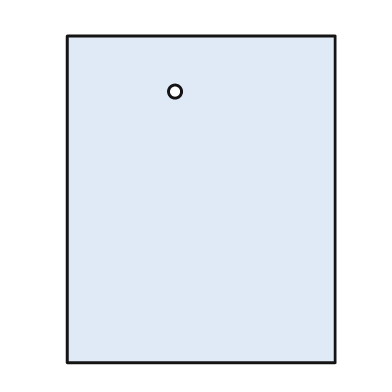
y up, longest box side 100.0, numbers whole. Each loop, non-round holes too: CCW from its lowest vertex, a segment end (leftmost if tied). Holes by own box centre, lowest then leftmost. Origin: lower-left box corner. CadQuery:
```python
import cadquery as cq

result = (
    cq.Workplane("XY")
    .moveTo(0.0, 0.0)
    .lineTo(82.0, 0.0)
    .lineTo(82.0, 100.0)
    .lineTo(0.0, 100.0)
    .close()
    .moveTo(33.0, 83.0)
    .circle(2.0)
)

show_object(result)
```